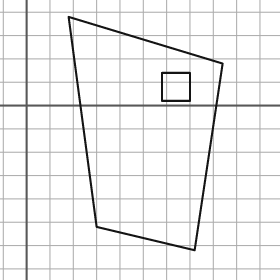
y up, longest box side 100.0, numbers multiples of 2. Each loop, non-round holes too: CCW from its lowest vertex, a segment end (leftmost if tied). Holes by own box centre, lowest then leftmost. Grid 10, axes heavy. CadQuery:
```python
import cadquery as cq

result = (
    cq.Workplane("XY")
    .moveTo(72.0, -62.0)
    .lineTo(84.0, 18.0)
    .lineTo(18.0, 38.0)
    .lineTo(30.0, -52.0)
    .close()
    .moveTo(58.0, 2.0)
    .lineTo(70.0, 2.0)
    .lineTo(70.0, 14.0)
    .lineTo(58.0, 14.0)
    .close()
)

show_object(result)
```